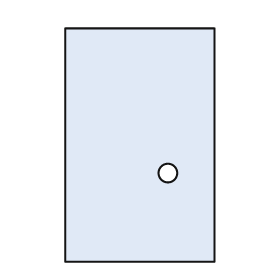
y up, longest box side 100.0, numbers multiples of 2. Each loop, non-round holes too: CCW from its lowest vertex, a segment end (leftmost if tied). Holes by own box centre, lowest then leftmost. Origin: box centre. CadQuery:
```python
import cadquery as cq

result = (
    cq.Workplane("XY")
    .moveTo(-32.0, -50.0)
    .lineTo(32.0, -50.0)
    .lineTo(32.0, 50.0)
    .lineTo(-32.0, 50.0)
    .close()
    .moveTo(12.0, -12.0)
    .circle(4.0)
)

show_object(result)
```